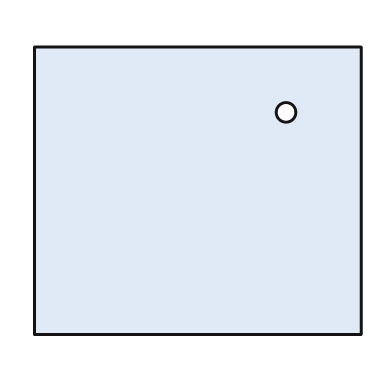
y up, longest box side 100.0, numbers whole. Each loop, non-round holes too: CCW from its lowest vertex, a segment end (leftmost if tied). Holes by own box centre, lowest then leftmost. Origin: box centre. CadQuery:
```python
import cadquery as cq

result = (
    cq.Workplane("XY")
    .moveTo(-50.0, -44.0)
    .lineTo(50.0, -44.0)
    .lineTo(50.0, 44.0)
    .lineTo(-50.0, 44.0)
    .close()
    .moveTo(27.0, 24.0)
    .circle(3.0)
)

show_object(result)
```